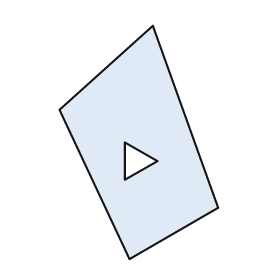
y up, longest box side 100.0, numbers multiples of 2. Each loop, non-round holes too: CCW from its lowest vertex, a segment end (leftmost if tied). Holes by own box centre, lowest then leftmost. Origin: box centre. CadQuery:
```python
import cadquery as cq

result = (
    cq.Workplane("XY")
    .moveTo(-4.0, -50.0)
    .lineTo(34.0, -28.0)
    .lineTo(6.0, 50.0)
    .lineTo(-34.0, 14.0)
    .close()
    .moveTo(-6.0, -16.0)
    .lineTo(8.0, -8.0)
    .lineTo(-6.0, 0.0)
    .close()
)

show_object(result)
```